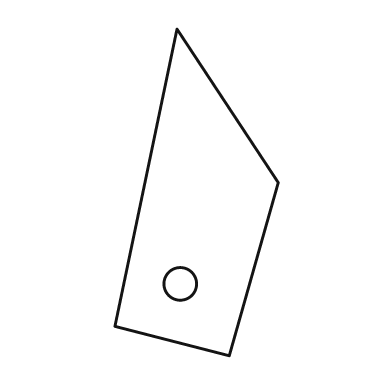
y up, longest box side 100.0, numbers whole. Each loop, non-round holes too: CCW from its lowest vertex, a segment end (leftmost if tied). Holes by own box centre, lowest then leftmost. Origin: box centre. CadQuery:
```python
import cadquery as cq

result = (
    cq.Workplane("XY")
    .moveTo(10.0, -50.0)
    .lineTo(25.0, 3.0)
    .lineTo(-6.0, 50.0)
    .lineTo(-25.0, -41.0)
    .close()
    .moveTo(-5.0, -28.0)
    .circle(5.0)
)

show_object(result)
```